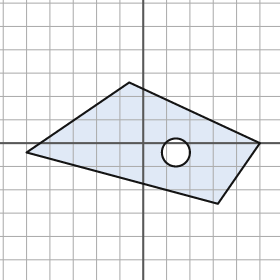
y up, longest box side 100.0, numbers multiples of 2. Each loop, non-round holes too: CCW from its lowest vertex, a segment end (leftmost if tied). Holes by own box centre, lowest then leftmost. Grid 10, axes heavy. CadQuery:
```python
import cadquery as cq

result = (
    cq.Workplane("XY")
    .moveTo(32.0, -26.0)
    .lineTo(50.0, 0.0)
    .lineTo(-6.0, 26.0)
    .lineTo(-50.0, -4.0)
    .close()
    .moveTo(14.0, -4.0)
    .circle(6.0)
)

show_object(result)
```